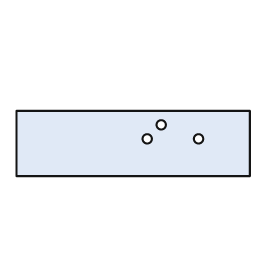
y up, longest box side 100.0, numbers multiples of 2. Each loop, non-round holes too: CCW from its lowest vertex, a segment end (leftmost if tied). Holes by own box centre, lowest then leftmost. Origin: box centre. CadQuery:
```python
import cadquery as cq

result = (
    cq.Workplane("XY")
    .moveTo(-50.0, -14.0)
    .lineTo(50.0, -14.0)
    .lineTo(50.0, 14.0)
    .lineTo(-50.0, 14.0)
    .close()
    .moveTo(6.0, 2.0)
    .circle(2.0)
    .moveTo(28.0, 2.0)
    .circle(2.0)
    .moveTo(12.0, 8.0)
    .circle(2.0)
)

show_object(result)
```